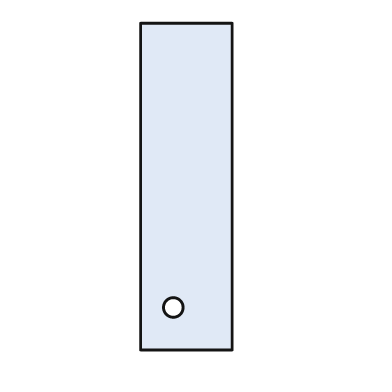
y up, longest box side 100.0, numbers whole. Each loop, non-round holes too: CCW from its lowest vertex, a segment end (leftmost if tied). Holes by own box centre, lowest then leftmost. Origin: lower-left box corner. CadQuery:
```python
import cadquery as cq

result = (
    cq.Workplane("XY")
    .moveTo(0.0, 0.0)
    .lineTo(28.0, 0.0)
    .lineTo(28.0, 100.0)
    .lineTo(0.0, 100.0)
    .close()
    .moveTo(10.0, 13.0)
    .circle(3.0)
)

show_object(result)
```